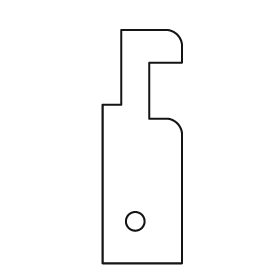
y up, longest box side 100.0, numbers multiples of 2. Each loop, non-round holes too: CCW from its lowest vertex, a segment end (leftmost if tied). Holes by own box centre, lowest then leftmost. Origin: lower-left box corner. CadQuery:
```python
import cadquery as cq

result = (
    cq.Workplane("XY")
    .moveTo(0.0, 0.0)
    .lineTo(34.0, 0.0)
    .lineTo(34.0, 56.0)
    .threePointArc((32.0, 60.0), (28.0, 62.0))
    .lineTo(20.0, 62.0)
    .lineTo(20.0, 86.0)
    .lineTo(34.0, 86.0)
    .lineTo(34.0, 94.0)
    .threePointArc((32.0, 98.0), (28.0, 100.0))
    .lineTo(8.0, 100.0)
    .lineTo(8.0, 68.0)
    .lineTo(0.0, 68.0)
    .close()
    .moveTo(14.0, 18.0)
    .circle(4.0)
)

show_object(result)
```